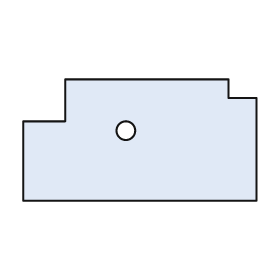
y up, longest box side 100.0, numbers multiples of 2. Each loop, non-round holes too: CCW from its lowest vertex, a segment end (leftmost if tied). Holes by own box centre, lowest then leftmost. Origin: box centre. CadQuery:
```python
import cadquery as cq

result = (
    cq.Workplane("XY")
    .moveTo(-50.0, -26.0)
    .lineTo(50.0, -26.0)
    .lineTo(50.0, 18.0)
    .lineTo(38.0, 18.0)
    .lineTo(38.0, 26.0)
    .lineTo(-32.0, 26.0)
    .lineTo(-32.0, 8.0)
    .lineTo(-50.0, 8.0)
    .close()
    .moveTo(-6.0, 4.0)
    .circle(4.0)
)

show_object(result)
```